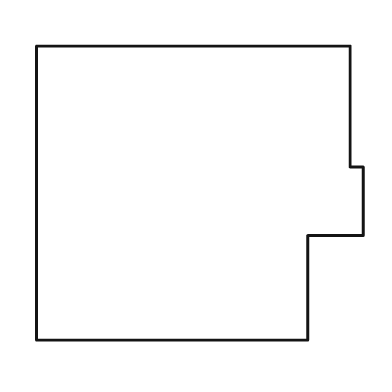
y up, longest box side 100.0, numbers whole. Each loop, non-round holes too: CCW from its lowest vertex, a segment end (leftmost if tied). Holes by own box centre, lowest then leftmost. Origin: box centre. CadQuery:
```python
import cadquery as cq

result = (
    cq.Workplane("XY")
    .moveTo(-50.0, -45.0)
    .lineTo(33.0, -45.0)
    .lineTo(33.0, -13.0)
    .lineTo(50.0, -13.0)
    .lineTo(50.0, 8.0)
    .lineTo(46.0, 8.0)
    .lineTo(46.0, 45.0)
    .lineTo(-50.0, 45.0)
    .close()
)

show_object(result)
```